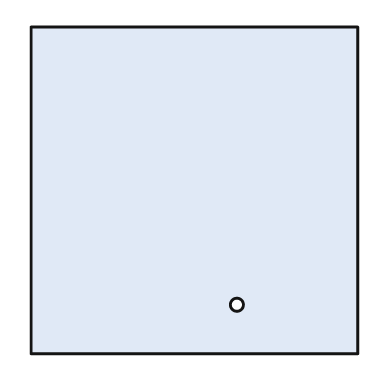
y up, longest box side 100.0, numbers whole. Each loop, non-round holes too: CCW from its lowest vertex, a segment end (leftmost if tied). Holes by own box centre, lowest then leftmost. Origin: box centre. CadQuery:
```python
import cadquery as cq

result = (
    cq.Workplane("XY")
    .moveTo(-50.0, -50.0)
    .lineTo(50.0, -50.0)
    .lineTo(50.0, 50.0)
    .lineTo(-50.0, 50.0)
    .close()
    .moveTo(13.0, -35.0)
    .circle(2.0)
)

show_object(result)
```